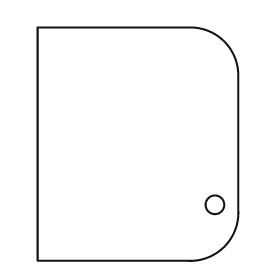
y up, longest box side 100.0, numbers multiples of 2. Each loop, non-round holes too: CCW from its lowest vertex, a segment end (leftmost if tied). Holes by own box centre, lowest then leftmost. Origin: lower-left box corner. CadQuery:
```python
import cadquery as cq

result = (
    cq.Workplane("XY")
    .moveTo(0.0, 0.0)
    .lineTo(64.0, 0.0)
    .threePointArc((80.0, 6.0), (86.0, 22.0))
    .lineTo(86.0, 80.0)
    .threePointArc((80.0, 94.0), (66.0, 100.0))
    .lineTo(0.0, 100.0)
    .close()
    .moveTo(76.0, 24.0)
    .circle(4.0)
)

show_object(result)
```